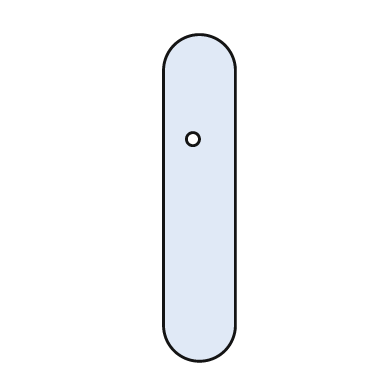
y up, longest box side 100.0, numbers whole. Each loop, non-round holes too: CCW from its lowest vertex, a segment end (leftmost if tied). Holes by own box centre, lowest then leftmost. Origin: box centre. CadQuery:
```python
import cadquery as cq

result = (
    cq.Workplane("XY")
    .moveTo(-11.0, -39.0)
    .threePointArc((0.0, -50.0), (11.0, -39.0))
    .lineTo(11.0, 39.0)
    .threePointArc((0.0, 50.0), (-11.0, 39.0))
    .close()
    .moveTo(-2.0, 18.0)
    .circle(2.0)
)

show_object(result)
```